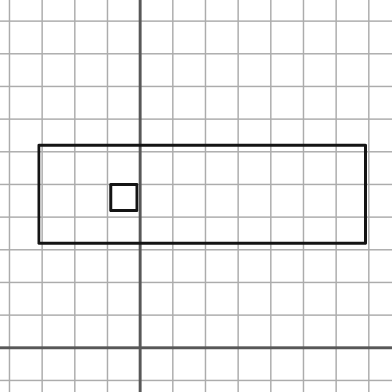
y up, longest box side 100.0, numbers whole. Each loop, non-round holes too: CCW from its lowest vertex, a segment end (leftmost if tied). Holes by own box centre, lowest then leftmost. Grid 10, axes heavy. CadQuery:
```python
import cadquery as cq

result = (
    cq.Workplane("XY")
    .moveTo(-31.0, 32.0)
    .lineTo(69.0, 32.0)
    .lineTo(69.0, 62.0)
    .lineTo(-31.0, 62.0)
    .close()
    .moveTo(-9.0, 42.0)
    .lineTo(-1.0, 42.0)
    .lineTo(-1.0, 50.0)
    .lineTo(-9.0, 50.0)
    .close()
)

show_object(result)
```